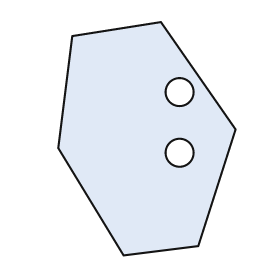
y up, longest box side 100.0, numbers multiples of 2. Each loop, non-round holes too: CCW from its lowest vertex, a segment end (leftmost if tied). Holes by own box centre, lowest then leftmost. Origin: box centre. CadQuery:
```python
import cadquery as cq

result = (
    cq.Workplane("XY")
    .moveTo(-10.0, -50.0)
    .lineTo(22.0, -46.0)
    .lineTo(38.0, 4.0)
    .lineTo(6.0, 50.0)
    .lineTo(-32.0, 44.0)
    .lineTo(-38.0, -4.0)
    .close()
    .moveTo(14.0, -6.0)
    .circle(6.0)
    .moveTo(14.0, 20.0)
    .circle(6.0)
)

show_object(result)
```